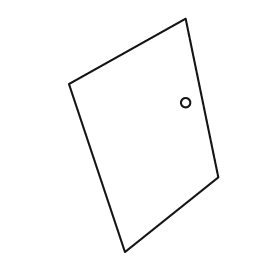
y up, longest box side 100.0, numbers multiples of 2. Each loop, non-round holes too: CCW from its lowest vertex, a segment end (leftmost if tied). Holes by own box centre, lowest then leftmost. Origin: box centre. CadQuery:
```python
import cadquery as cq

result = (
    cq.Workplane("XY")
    .moveTo(-8.0, -50.0)
    .lineTo(32.0, -18.0)
    .lineTo(18.0, 50.0)
    .lineTo(-32.0, 22.0)
    .close()
    .moveTo(18.0, 14.0)
    .circle(2.0)
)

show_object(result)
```